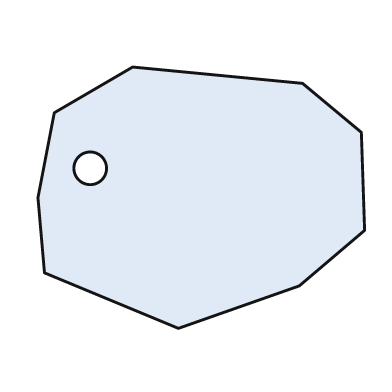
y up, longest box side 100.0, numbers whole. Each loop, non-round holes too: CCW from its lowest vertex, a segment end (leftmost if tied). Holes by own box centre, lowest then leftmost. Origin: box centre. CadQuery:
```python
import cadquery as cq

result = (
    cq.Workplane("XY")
    .moveTo(-7.0, -40.0)
    .lineTo(30.0, -27.0)
    .lineTo(50.0, -10.0)
    .lineTo(49.0, 20.0)
    .lineTo(31.0, 35.0)
    .lineTo(-21.0, 40.0)
    .lineTo(-45.0, 26.0)
    .lineTo(-50.0, 0.0)
    .lineTo(-48.0, -23.0)
    .close()
    .moveTo(-34.0, 9.0)
    .circle(5.0)
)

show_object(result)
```